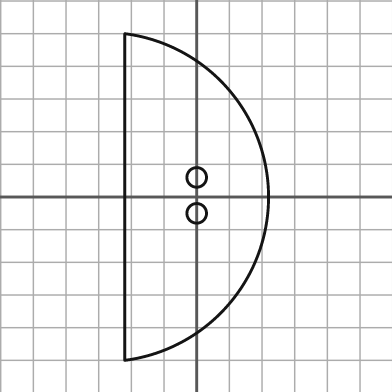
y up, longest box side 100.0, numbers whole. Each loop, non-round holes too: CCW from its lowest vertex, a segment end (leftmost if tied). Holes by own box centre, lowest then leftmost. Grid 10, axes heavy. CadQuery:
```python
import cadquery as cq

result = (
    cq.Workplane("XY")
    .moveTo(-22.0, -50.0)
    .threePointArc((22.0, 0.0), (-22.0, 50.0))
    .close()
    .moveTo(0.0, -5.0)
    .circle(3.0)
    .moveTo(0.0, 6.0)
    .circle(3.0)
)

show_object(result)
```